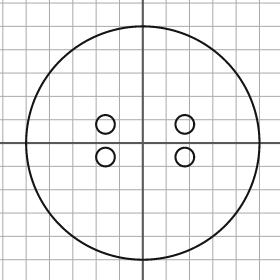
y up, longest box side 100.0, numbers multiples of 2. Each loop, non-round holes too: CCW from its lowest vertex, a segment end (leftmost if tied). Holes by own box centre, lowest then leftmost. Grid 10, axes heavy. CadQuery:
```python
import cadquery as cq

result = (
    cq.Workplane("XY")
    .moveTo(0.0, 0.0)
    .circle(50.0)
    .moveTo(-16.0, -6.0)
    .circle(4.0)
    .moveTo(18.0, -6.0)
    .circle(4.0)
    .moveTo(-16.0, 8.0)
    .circle(4.0)
    .moveTo(18.0, 8.0)
    .circle(4.0)
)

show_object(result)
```